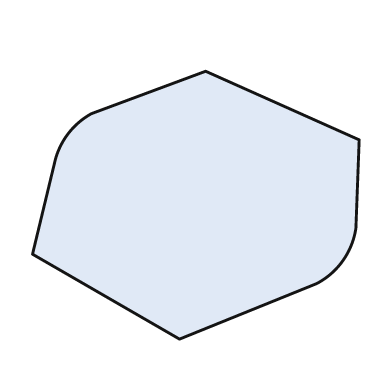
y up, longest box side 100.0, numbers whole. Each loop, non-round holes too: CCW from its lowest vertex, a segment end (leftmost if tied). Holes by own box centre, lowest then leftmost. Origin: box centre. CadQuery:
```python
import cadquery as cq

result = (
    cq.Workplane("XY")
    .moveTo(-5.0, -41.0)
    .lineTo(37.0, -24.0)
    .threePointArc((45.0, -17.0), (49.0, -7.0))
    .lineTo(50.0, 20.0)
    .lineTo(3.0, 41.0)
    .lineTo(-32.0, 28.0)
    .threePointArc((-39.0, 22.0), (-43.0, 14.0))
    .lineTo(-50.0, -15.0)
    .close()
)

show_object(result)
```